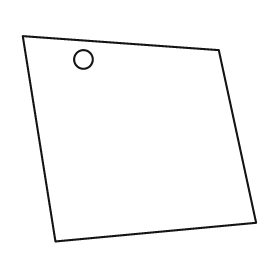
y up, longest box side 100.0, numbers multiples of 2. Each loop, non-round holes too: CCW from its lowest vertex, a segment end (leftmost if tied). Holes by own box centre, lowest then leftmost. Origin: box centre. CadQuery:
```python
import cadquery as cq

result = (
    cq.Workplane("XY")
    .moveTo(-36.0, -44.0)
    .lineTo(50.0, -36.0)
    .lineTo(34.0, 38.0)
    .lineTo(-50.0, 44.0)
    .close()
    .moveTo(-24.0, 34.0)
    .circle(4.0)
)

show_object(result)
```